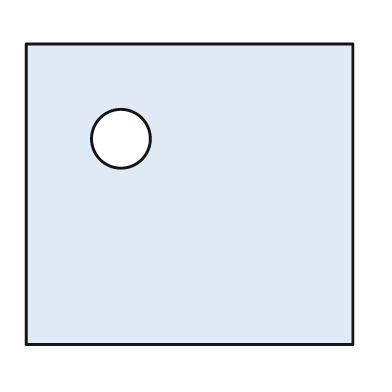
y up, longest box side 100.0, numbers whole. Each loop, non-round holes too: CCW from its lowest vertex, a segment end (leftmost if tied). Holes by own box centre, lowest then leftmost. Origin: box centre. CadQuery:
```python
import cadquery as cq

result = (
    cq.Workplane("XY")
    .moveTo(-50.0, -46.0)
    .lineTo(50.0, -46.0)
    .lineTo(50.0, 46.0)
    .lineTo(-50.0, 46.0)
    .close()
    .moveTo(-21.0, 17.0)
    .circle(9.0)
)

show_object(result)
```